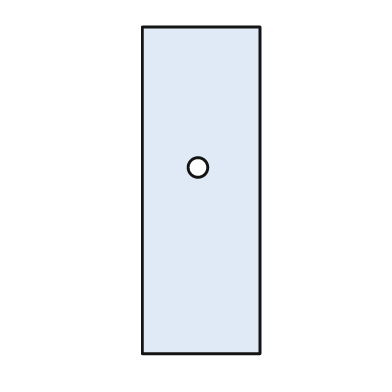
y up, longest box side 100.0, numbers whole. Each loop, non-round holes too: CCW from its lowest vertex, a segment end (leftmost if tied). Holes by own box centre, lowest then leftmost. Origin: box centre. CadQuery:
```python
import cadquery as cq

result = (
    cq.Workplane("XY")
    .moveTo(-18.0, -50.0)
    .lineTo(18.0, -50.0)
    .lineTo(18.0, 50.0)
    .lineTo(-18.0, 50.0)
    .close()
    .moveTo(-1.0, 7.0)
    .circle(3.0)
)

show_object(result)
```